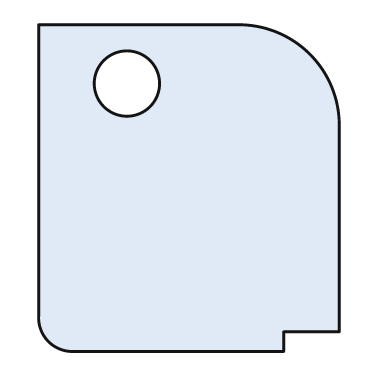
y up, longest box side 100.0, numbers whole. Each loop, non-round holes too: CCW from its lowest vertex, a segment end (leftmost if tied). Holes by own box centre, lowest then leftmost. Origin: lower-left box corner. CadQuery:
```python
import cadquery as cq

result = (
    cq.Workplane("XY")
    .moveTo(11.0, 0.0)
    .lineTo(75.0, 0.0)
    .lineTo(75.0, 6.0)
    .lineTo(92.0, 6.0)
    .lineTo(92.0, 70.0)
    .threePointArc((83.0, 91.0), (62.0, 100.0))
    .lineTo(0.0, 100.0)
    .lineTo(0.0, 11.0)
    .threePointArc((3.0, 3.0), (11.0, 0.0))
    .close()
    .moveTo(27.0, 82.0)
    .circle(10.0)
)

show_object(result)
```